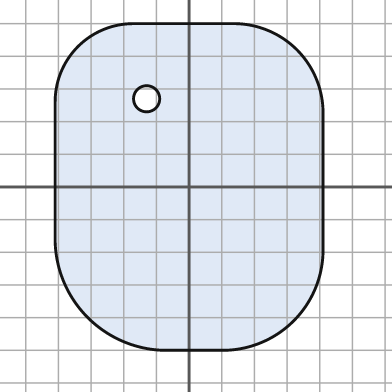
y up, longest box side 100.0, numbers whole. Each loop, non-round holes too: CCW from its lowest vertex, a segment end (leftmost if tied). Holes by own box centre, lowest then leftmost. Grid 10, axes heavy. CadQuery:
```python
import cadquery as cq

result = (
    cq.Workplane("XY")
    .moveTo(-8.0, -50.0)
    .lineTo(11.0, -50.0)
    .threePointArc((32.0, -41.0), (41.0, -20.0))
    .lineTo(41.0, 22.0)
    .threePointArc((33.0, 42.0), (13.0, 50.0))
    .lineTo(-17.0, 50.0)
    .threePointArc((-34.0, 43.0), (-41.0, 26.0))
    .lineTo(-41.0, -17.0)
    .threePointArc((-31.0, -40.0), (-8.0, -50.0))
    .close()
    .moveTo(-13.0, 27.0)
    .circle(4.0)
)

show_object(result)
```